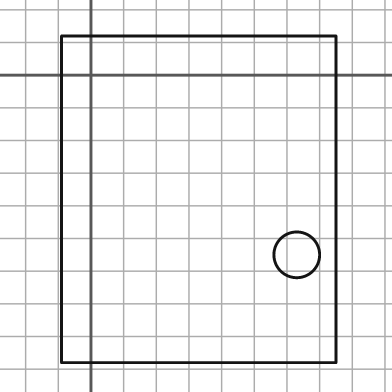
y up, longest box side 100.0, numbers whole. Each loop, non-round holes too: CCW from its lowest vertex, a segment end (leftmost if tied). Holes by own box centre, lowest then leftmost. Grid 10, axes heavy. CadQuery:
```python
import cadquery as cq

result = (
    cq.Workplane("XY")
    .moveTo(-9.0, -88.0)
    .lineTo(75.0, -88.0)
    .lineTo(75.0, 12.0)
    .lineTo(-9.0, 12.0)
    .close()
    .moveTo(63.0, -55.0)
    .circle(7.0)
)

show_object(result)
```